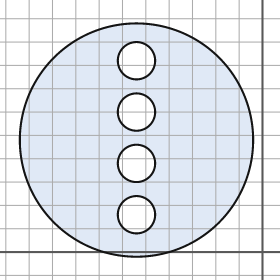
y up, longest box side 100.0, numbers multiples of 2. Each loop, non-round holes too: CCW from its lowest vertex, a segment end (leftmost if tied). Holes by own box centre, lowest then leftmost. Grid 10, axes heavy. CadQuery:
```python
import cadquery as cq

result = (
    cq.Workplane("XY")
    .moveTo(-54.0, 48.0)
    .circle(50.0)
    .moveTo(-54.0, 16.0)
    .circle(8.0)
    .moveTo(-54.0, 38.0)
    .circle(8.0)
    .moveTo(-54.0, 60.0)
    .circle(8.0)
    .moveTo(-54.0, 82.0)
    .circle(8.0)
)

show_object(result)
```